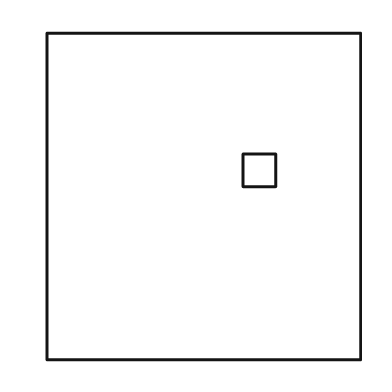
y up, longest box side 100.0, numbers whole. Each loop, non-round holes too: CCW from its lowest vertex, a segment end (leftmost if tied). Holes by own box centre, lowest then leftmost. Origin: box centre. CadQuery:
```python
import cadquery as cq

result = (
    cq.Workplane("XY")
    .moveTo(-48.0, -50.0)
    .lineTo(48.0, -50.0)
    .lineTo(48.0, 50.0)
    .lineTo(-48.0, 50.0)
    .close()
    .moveTo(12.0, 3.0)
    .lineTo(22.0, 3.0)
    .lineTo(22.0, 13.0)
    .lineTo(12.0, 13.0)
    .close()
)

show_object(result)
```